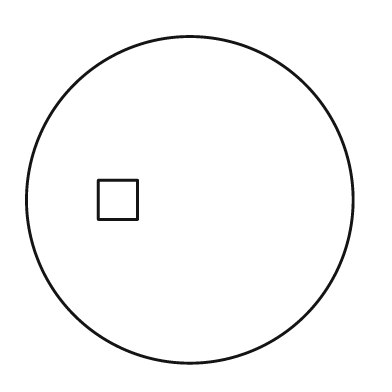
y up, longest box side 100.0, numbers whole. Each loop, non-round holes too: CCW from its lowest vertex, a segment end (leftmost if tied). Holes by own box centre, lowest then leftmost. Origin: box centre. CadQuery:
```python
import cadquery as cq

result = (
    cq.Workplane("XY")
    .moveTo(0.0, 0.0)
    .circle(50.0)
    .moveTo(-28.0, -6.0)
    .lineTo(-16.0, -6.0)
    .lineTo(-16.0, 6.0)
    .lineTo(-28.0, 6.0)
    .close()
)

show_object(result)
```